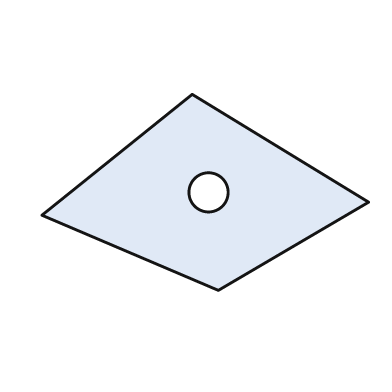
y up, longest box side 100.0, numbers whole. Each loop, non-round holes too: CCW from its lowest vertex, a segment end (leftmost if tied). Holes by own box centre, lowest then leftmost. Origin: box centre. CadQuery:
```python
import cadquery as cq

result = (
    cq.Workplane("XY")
    .moveTo(4.0, -30.0)
    .lineTo(50.0, -3.0)
    .lineTo(-4.0, 30.0)
    .lineTo(-50.0, -7.0)
    .close()
    .moveTo(1.0, 0.0)
    .circle(6.0)
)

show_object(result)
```